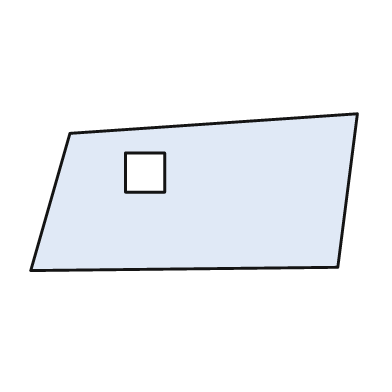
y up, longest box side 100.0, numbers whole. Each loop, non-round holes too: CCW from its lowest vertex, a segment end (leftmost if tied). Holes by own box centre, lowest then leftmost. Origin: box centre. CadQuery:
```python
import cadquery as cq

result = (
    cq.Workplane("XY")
    .moveTo(-50.0, -24.0)
    .lineTo(44.0, -23.0)
    .lineTo(50.0, 24.0)
    .lineTo(-38.0, 18.0)
    .close()
    .moveTo(-21.0, 0.0)
    .lineTo(-9.0, 0.0)
    .lineTo(-9.0, 12.0)
    .lineTo(-21.0, 12.0)
    .close()
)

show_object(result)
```